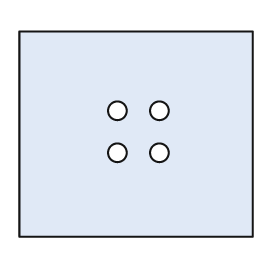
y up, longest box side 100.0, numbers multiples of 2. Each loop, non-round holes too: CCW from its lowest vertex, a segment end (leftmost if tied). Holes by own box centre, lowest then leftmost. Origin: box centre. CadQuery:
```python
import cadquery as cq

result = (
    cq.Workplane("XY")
    .moveTo(-50.0, -44.0)
    .lineTo(50.0, -44.0)
    .lineTo(50.0, 44.0)
    .lineTo(-50.0, 44.0)
    .close()
    .moveTo(-8.0, -8.0)
    .circle(4.0)
    .moveTo(10.0, -8.0)
    .circle(4.0)
    .moveTo(-8.0, 10.0)
    .circle(4.0)
    .moveTo(10.0, 10.0)
    .circle(4.0)
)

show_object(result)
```